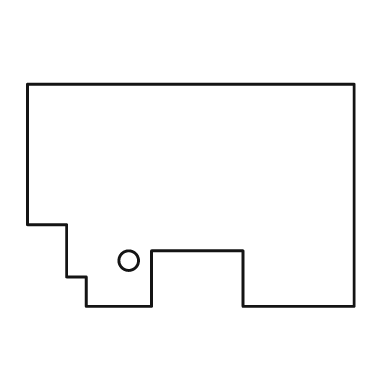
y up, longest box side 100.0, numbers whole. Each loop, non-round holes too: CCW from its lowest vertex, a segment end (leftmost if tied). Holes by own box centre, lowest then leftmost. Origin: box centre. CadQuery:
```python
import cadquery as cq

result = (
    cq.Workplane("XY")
    .moveTo(-32.0, -34.0)
    .lineTo(-12.0, -34.0)
    .lineTo(-12.0, -17.0)
    .lineTo(16.0, -17.0)
    .lineTo(16.0, -34.0)
    .lineTo(50.0, -34.0)
    .lineTo(50.0, 34.0)
    .lineTo(-50.0, 34.0)
    .lineTo(-50.0, -9.0)
    .lineTo(-38.0, -9.0)
    .lineTo(-38.0, -25.0)
    .lineTo(-32.0, -25.0)
    .close()
    .moveTo(-19.0, -20.0)
    .circle(3.0)
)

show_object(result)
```